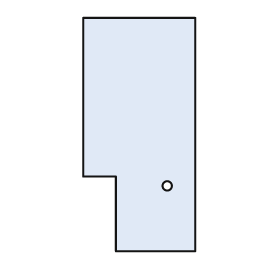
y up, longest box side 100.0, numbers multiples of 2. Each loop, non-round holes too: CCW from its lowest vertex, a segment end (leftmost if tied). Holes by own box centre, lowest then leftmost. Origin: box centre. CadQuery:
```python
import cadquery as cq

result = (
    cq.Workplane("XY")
    .moveTo(-10.0, -50.0)
    .lineTo(24.0, -50.0)
    .lineTo(24.0, 50.0)
    .lineTo(-24.0, 50.0)
    .lineTo(-24.0, -18.0)
    .lineTo(-10.0, -18.0)
    .close()
    .moveTo(12.0, -22.0)
    .circle(2.0)
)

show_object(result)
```